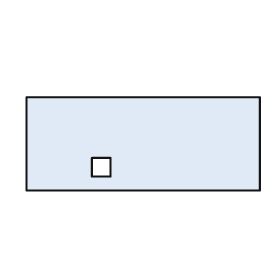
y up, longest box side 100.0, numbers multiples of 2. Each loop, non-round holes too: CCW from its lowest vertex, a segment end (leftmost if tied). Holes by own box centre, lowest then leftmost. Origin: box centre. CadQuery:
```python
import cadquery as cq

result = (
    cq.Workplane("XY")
    .moveTo(-50.0, -20.0)
    .lineTo(50.0, -20.0)
    .lineTo(50.0, 20.0)
    .lineTo(-50.0, 20.0)
    .close()
    .moveTo(-22.0, -14.0)
    .lineTo(-14.0, -14.0)
    .lineTo(-14.0, -6.0)
    .lineTo(-22.0, -6.0)
    .close()
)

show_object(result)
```